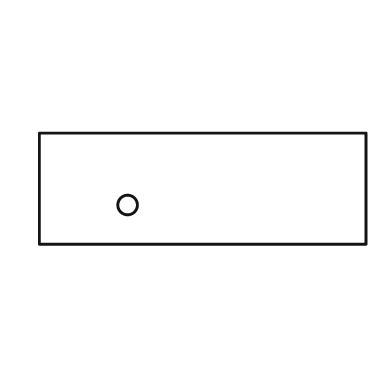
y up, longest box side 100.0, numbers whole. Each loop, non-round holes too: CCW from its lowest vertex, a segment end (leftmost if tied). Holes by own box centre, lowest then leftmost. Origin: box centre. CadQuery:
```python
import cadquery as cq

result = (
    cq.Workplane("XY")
    .moveTo(-50.0, -17.0)
    .lineTo(50.0, -17.0)
    .lineTo(50.0, 17.0)
    .lineTo(-50.0, 17.0)
    .close()
    .moveTo(-23.0, -5.0)
    .circle(3.0)
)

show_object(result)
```